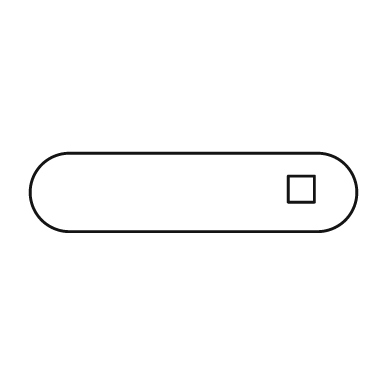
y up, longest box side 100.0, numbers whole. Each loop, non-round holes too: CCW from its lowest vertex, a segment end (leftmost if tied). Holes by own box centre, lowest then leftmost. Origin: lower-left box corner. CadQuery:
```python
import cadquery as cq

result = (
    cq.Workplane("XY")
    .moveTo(12.0, 0.0)
    .lineTo(88.0, 0.0)
    .threePointArc((100.0, 12.0), (88.0, 24.0))
    .lineTo(12.0, 24.0)
    .threePointArc((0.0, 12.0), (12.0, 0.0))
    .close()
    .moveTo(79.0, 9.0)
    .lineTo(87.0, 9.0)
    .lineTo(87.0, 17.0)
    .lineTo(79.0, 17.0)
    .close()
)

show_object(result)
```